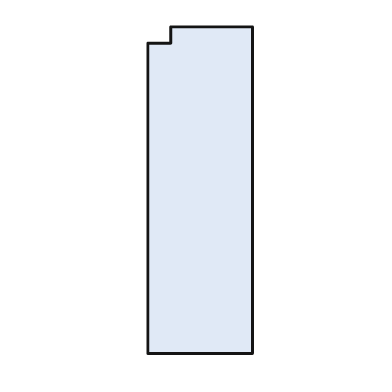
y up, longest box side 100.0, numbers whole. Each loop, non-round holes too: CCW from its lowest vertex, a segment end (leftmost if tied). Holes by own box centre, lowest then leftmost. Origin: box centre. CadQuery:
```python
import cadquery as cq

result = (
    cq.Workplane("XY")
    .moveTo(-16.0, -50.0)
    .lineTo(16.0, -50.0)
    .lineTo(16.0, 50.0)
    .lineTo(-9.0, 50.0)
    .lineTo(-9.0, 45.0)
    .lineTo(-16.0, 45.0)
    .close()
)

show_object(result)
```